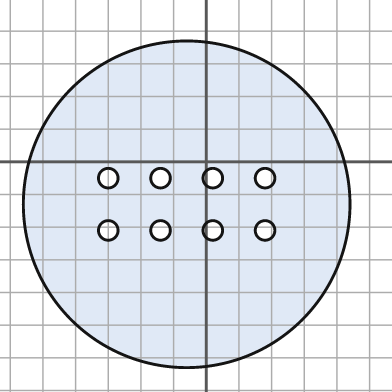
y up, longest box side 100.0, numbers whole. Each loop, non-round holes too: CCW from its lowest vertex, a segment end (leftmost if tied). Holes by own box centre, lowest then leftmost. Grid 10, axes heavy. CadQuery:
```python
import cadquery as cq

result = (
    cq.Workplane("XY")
    .moveTo(-6.0, -13.0)
    .circle(50.0)
    .moveTo(-30.0, -21.0)
    .circle(3.0)
    .moveTo(-14.0, -21.0)
    .circle(3.0)
    .moveTo(2.0, -21.0)
    .circle(3.0)
    .moveTo(18.0, -21.0)
    .circle(3.0)
    .moveTo(-30.0, -5.0)
    .circle(3.0)
    .moveTo(-14.0, -5.0)
    .circle(3.0)
    .moveTo(2.0, -5.0)
    .circle(3.0)
    .moveTo(18.0, -5.0)
    .circle(3.0)
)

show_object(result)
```